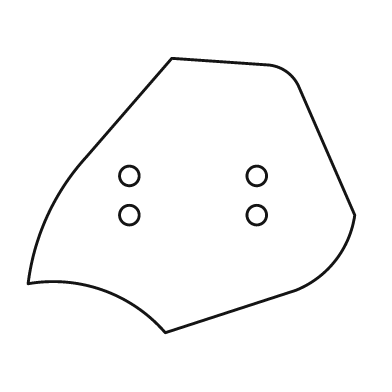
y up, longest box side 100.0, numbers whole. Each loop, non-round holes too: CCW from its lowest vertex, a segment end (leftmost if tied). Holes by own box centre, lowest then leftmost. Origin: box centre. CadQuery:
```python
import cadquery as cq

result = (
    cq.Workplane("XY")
    .moveTo(-8.0, -42.0)
    .lineTo(32.0, -29.0)
    .threePointArc((44.0, -20.0), (50.0, -6.0))
    .lineTo(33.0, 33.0)
    .threePointArc((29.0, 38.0), (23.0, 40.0))
    .lineTo(-6.0, 42.0)
    .lineTo(-32.0, 12.0)
    .threePointArc((-44.0, -6.0), (-50.0, -27.0))
    .threePointArc((-27.0, -29.0), (-8.0, -42.0))
    .close()
    .moveTo(-19.0, -6.0)
    .circle(3.0)
    .moveTo(20.0, -6.0)
    .circle(3.0)
    .moveTo(-19.0, 6.0)
    .circle(3.0)
    .moveTo(20.0, 6.0)
    .circle(3.0)
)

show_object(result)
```